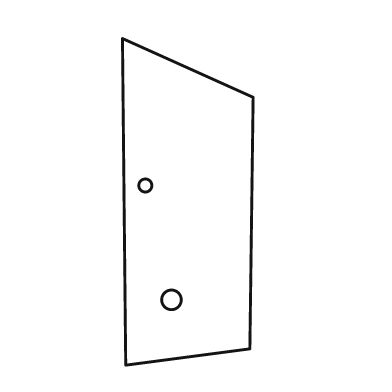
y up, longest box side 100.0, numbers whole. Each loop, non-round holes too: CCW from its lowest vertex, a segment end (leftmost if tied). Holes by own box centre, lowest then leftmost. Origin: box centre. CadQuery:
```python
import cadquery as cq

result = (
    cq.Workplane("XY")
    .moveTo(-19.0, -50.0)
    .lineTo(19.0, -45.0)
    .lineTo(20.0, 32.0)
    .lineTo(-20.0, 50.0)
    .close()
    .moveTo(-5.0, -30.0)
    .circle(3.0)
    .moveTo(-13.0, 5.0)
    .circle(2.0)
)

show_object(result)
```